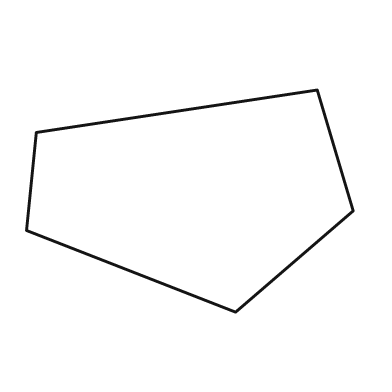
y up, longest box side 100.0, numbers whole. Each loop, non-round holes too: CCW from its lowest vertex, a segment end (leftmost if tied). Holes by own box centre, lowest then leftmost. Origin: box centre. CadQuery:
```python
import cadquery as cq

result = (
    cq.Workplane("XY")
    .moveTo(14.0, -34.0)
    .lineTo(50.0, -3.0)
    .lineTo(39.0, 34.0)
    .lineTo(-47.0, 21.0)
    .lineTo(-50.0, -9.0)
    .close()
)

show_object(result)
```